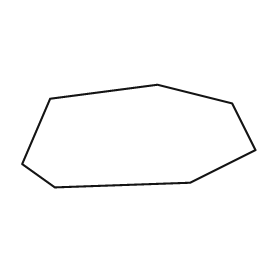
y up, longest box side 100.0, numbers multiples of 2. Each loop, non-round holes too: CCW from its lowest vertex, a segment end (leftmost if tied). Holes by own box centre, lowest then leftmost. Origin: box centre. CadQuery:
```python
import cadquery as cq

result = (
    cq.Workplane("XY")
    .moveTo(-36.0, -22.0)
    .lineTo(22.0, -20.0)
    .lineTo(50.0, -6.0)
    .lineTo(40.0, 14.0)
    .lineTo(8.0, 22.0)
    .lineTo(-38.0, 16.0)
    .lineTo(-50.0, -12.0)
    .close()
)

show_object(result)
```